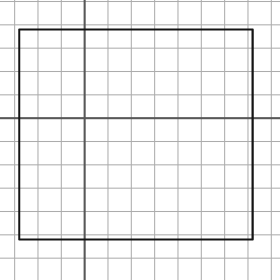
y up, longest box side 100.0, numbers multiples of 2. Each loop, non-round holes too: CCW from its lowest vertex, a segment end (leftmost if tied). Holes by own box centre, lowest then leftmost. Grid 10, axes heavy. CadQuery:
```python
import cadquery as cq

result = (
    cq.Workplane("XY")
    .moveTo(-28.0, -52.0)
    .lineTo(72.0, -52.0)
    .lineTo(72.0, 38.0)
    .lineTo(-28.0, 38.0)
    .close()
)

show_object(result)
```